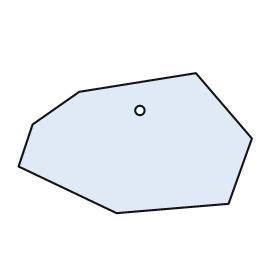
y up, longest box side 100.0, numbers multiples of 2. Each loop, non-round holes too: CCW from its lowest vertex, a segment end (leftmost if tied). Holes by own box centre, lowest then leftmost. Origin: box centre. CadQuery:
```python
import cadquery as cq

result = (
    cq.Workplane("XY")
    .moveTo(-8.0, -30.0)
    .lineTo(40.0, -26.0)
    .lineTo(50.0, 2.0)
    .lineTo(26.0, 30.0)
    .lineTo(-24.0, 22.0)
    .lineTo(-44.0, 8.0)
    .lineTo(-50.0, -10.0)
    .close()
    .moveTo(2.0, 14.0)
    .circle(2.0)
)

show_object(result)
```